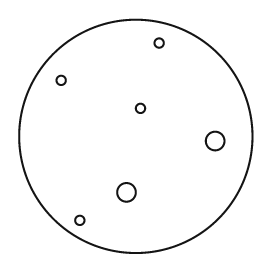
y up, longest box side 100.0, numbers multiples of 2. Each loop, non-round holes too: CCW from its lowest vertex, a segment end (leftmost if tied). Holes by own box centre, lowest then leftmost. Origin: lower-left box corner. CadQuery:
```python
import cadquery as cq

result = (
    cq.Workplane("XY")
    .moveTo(50.0, 50.0)
    .circle(50.0)
    .moveTo(26.0, 14.0)
    .circle(2.0)
    .moveTo(46.0, 26.0)
    .circle(4.0)
    .moveTo(84.0, 48.0)
    .circle(4.0)
    .moveTo(52.0, 62.0)
    .circle(2.0)
    .moveTo(18.0, 74.0)
    .circle(2.0)
    .moveTo(60.0, 90.0)
    .circle(2.0)
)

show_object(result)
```